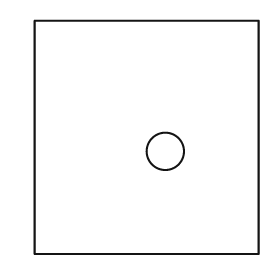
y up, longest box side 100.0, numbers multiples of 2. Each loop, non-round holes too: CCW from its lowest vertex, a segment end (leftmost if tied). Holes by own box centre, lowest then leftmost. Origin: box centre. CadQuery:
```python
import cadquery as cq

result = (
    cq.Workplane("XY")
    .moveTo(-48.0, -50.0)
    .lineTo(48.0, -50.0)
    .lineTo(48.0, 50.0)
    .lineTo(-48.0, 50.0)
    .close()
    .moveTo(8.0, -6.0)
    .circle(8.0)
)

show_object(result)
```